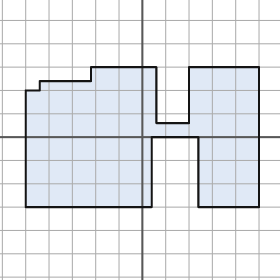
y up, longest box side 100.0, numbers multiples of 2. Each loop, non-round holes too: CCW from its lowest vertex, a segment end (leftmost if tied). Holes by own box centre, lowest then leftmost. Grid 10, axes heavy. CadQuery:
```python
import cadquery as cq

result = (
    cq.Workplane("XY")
    .moveTo(-50.0, -30.0)
    .lineTo(4.0, -30.0)
    .lineTo(4.0, 0.0)
    .lineTo(24.0, 0.0)
    .lineTo(24.0, -30.0)
    .lineTo(50.0, -30.0)
    .lineTo(50.0, 30.0)
    .lineTo(20.0, 30.0)
    .lineTo(20.0, 6.0)
    .lineTo(6.0, 6.0)
    .lineTo(6.0, 30.0)
    .lineTo(-22.0, 30.0)
    .lineTo(-22.0, 24.0)
    .lineTo(-44.0, 24.0)
    .lineTo(-44.0, 20.0)
    .lineTo(-50.0, 20.0)
    .close()
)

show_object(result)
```